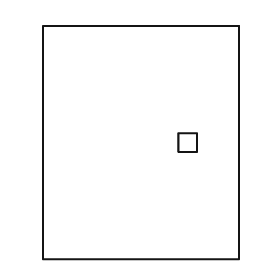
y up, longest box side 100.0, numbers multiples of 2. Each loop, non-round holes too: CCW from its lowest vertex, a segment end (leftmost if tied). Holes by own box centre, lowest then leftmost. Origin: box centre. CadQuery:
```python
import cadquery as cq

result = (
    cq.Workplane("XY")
    .moveTo(-42.0, -50.0)
    .lineTo(42.0, -50.0)
    .lineTo(42.0, 50.0)
    .lineTo(-42.0, 50.0)
    .close()
    .moveTo(16.0, -4.0)
    .lineTo(24.0, -4.0)
    .lineTo(24.0, 4.0)
    .lineTo(16.0, 4.0)
    .close()
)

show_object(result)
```